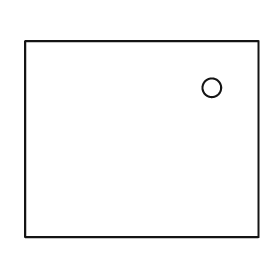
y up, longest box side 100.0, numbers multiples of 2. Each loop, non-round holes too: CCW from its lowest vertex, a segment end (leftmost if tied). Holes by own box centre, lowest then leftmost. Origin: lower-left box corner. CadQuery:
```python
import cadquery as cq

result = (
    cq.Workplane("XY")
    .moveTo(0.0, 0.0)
    .lineTo(100.0, 0.0)
    .lineTo(100.0, 84.0)
    .lineTo(0.0, 84.0)
    .close()
    .moveTo(80.0, 64.0)
    .circle(4.0)
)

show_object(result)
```